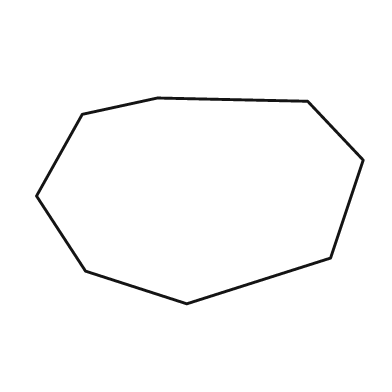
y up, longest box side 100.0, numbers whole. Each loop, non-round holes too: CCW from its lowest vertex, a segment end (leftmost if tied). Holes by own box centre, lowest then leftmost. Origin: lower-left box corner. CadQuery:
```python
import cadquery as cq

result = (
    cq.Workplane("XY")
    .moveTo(46.0, 0.0)
    .lineTo(90.0, 14.0)
    .lineTo(100.0, 44.0)
    .lineTo(83.0, 62.0)
    .lineTo(37.0, 63.0)
    .lineTo(14.0, 58.0)
    .lineTo(0.0, 33.0)
    .lineTo(15.0, 10.0)
    .close()
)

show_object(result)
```